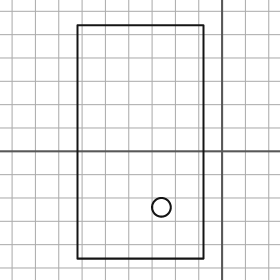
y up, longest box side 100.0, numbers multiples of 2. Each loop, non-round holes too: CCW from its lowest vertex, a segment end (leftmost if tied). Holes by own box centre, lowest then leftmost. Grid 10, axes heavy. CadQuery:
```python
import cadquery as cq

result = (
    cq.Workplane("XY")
    .moveTo(-62.0, -46.0)
    .lineTo(-8.0, -46.0)
    .lineTo(-8.0, 54.0)
    .lineTo(-62.0, 54.0)
    .close()
    .moveTo(-26.0, -24.0)
    .circle(4.0)
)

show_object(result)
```